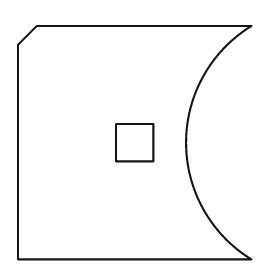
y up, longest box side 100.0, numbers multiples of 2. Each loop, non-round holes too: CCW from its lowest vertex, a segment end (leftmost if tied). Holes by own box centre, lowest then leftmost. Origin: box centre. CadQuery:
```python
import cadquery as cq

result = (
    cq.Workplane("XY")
    .moveTo(-50.0, -50.0)
    .lineTo(50.0, -50.0)
    .threePointArc((22.0, 0.0), (50.0, 50.0))
    .lineTo(-42.0, 50.0)
    .lineTo(-50.0, 42.0)
    .close()
    .moveTo(-8.0, -8.0)
    .lineTo(8.0, -8.0)
    .lineTo(8.0, 8.0)
    .lineTo(-8.0, 8.0)
    .close()
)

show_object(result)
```